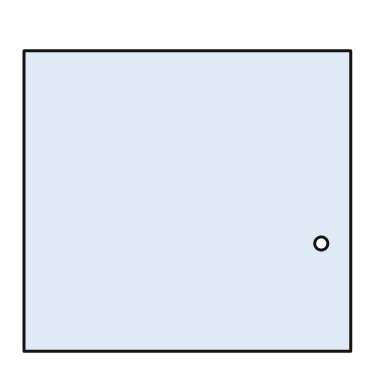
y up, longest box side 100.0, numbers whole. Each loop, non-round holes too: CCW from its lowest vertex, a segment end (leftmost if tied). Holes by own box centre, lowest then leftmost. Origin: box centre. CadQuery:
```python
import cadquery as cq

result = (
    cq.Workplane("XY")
    .moveTo(-50.0, -46.0)
    .lineTo(50.0, -46.0)
    .lineTo(50.0, 46.0)
    .lineTo(-50.0, 46.0)
    .close()
    .moveTo(41.0, -13.0)
    .circle(2.0)
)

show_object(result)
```